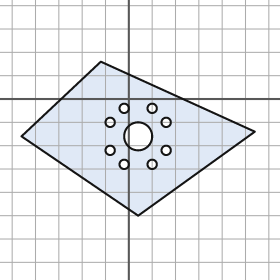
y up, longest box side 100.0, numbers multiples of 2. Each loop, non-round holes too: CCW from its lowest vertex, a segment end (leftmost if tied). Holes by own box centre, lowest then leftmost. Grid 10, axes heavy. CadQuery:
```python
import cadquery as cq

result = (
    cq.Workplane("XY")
    .moveTo(4.0, -50.0)
    .lineTo(54.0, -14.0)
    .lineTo(-12.0, 16.0)
    .lineTo(-46.0, -16.0)
    .close()
    .moveTo(-2.0, -28.0)
    .circle(2.0)
    .moveTo(10.0, -28.0)
    .circle(2.0)
    .moveTo(-8.0, -22.0)
    .circle(2.0)
    .moveTo(16.0, -22.0)
    .circle(2.0)
    .moveTo(4.0, -16.0)
    .circle(6.0)
    .moveTo(-8.0, -10.0)
    .circle(2.0)
    .moveTo(16.0, -10.0)
    .circle(2.0)
    .moveTo(-2.0, -4.0)
    .circle(2.0)
    .moveTo(10.0, -4.0)
    .circle(2.0)
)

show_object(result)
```